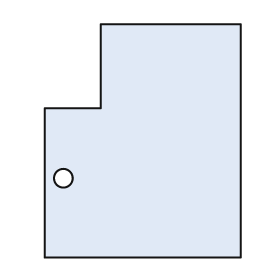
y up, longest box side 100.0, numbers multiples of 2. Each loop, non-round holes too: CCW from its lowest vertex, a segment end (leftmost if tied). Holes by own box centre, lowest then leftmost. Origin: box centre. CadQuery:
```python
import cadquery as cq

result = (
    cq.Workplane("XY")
    .moveTo(-42.0, -50.0)
    .lineTo(42.0, -50.0)
    .lineTo(42.0, 50.0)
    .lineTo(-18.0, 50.0)
    .lineTo(-18.0, 14.0)
    .lineTo(-42.0, 14.0)
    .close()
    .moveTo(-34.0, -16.0)
    .circle(4.0)
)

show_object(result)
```